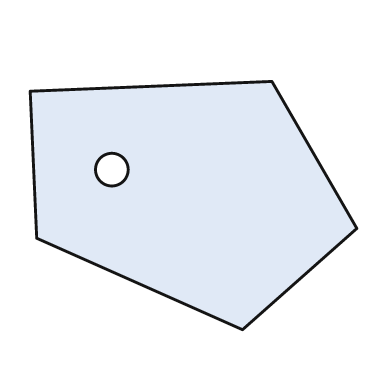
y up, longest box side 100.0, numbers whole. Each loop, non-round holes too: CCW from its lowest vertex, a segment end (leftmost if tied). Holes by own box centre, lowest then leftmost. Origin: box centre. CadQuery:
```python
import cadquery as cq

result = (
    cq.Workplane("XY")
    .moveTo(15.0, -38.0)
    .lineTo(50.0, -7.0)
    .lineTo(24.0, 38.0)
    .lineTo(-50.0, 35.0)
    .lineTo(-48.0, -10.0)
    .close()
    .moveTo(-25.0, 11.0)
    .circle(5.0)
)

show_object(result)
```